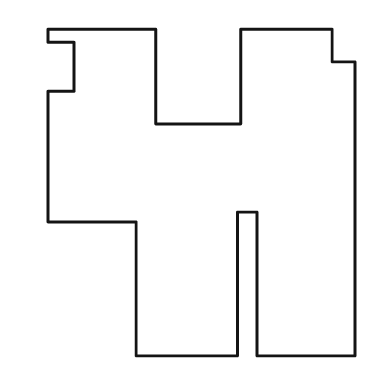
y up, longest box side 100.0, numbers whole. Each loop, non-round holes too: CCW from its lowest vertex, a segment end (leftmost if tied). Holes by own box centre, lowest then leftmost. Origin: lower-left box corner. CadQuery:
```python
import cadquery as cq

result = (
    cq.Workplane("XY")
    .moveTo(27.0, 0.0)
    .lineTo(58.0, 0.0)
    .lineTo(58.0, 44.0)
    .lineTo(64.0, 44.0)
    .lineTo(64.0, 0.0)
    .lineTo(94.0, 0.0)
    .lineTo(94.0, 90.0)
    .lineTo(87.0, 90.0)
    .lineTo(87.0, 100.0)
    .lineTo(59.0, 100.0)
    .lineTo(59.0, 71.0)
    .lineTo(33.0, 71.0)
    .lineTo(33.0, 100.0)
    .lineTo(0.0, 100.0)
    .lineTo(0.0, 96.0)
    .lineTo(8.0, 96.0)
    .lineTo(8.0, 81.0)
    .lineTo(0.0, 81.0)
    .lineTo(0.0, 41.0)
    .lineTo(27.0, 41.0)
    .close()
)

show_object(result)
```